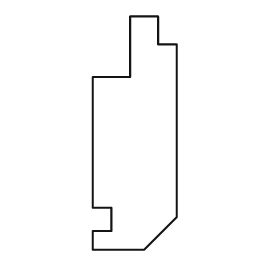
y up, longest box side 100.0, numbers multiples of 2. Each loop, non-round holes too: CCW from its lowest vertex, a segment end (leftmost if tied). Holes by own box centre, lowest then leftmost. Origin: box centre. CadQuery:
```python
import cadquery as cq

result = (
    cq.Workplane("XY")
    .moveTo(-18.0, -50.0)
    .lineTo(4.0, -50.0)
    .lineTo(18.0, -36.0)
    .lineTo(18.0, 38.0)
    .lineTo(10.0, 38.0)
    .lineTo(10.0, 50.0)
    .lineTo(-2.0, 50.0)
    .lineTo(-2.0, 24.0)
    .lineTo(-18.0, 24.0)
    .lineTo(-18.0, -32.0)
    .lineTo(-10.0, -32.0)
    .lineTo(-10.0, -42.0)
    .lineTo(-18.0, -42.0)
    .close()
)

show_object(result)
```